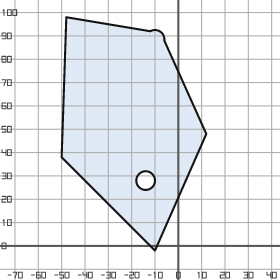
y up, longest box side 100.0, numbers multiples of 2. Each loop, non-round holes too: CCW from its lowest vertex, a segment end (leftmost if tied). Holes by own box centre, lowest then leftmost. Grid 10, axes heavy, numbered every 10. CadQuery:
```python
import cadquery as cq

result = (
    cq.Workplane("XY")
    .moveTo(-10.0, -2.0)
    .lineTo(12.0, 48.0)
    .lineTo(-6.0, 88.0)
    .threePointArc((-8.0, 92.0), (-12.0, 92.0))
    .lineTo(-48.0, 98.0)
    .lineTo(-50.0, 38.0)
    .close()
    .moveTo(-14.0, 28.0)
    .circle(4.0)
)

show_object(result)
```